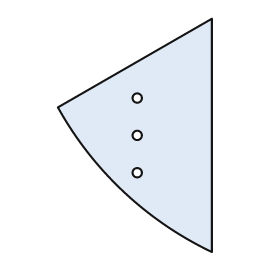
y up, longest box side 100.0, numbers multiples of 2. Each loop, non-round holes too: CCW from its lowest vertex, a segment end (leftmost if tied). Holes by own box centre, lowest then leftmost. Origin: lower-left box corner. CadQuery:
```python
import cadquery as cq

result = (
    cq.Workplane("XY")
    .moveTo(66.0, 0.0)
    .lineTo(66.0, 100.0)
    .lineTo(0.0, 62.0)
    .threePointArc((28.0, 26.0), (66.0, 0.0))
    .close()
    .moveTo(34.0, 34.0)
    .circle(2.0)
    .moveTo(34.0, 50.0)
    .circle(2.0)
    .moveTo(34.0, 66.0)
    .circle(2.0)
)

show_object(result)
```